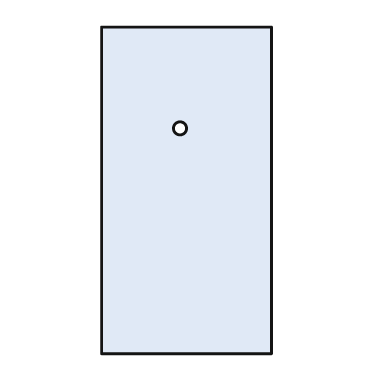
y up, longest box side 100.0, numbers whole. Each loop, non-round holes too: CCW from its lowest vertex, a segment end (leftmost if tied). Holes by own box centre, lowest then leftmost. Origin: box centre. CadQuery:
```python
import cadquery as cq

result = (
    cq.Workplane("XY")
    .moveTo(-26.0, -50.0)
    .lineTo(26.0, -50.0)
    .lineTo(26.0, 50.0)
    .lineTo(-26.0, 50.0)
    .close()
    .moveTo(-2.0, 19.0)
    .circle(2.0)
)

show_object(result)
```